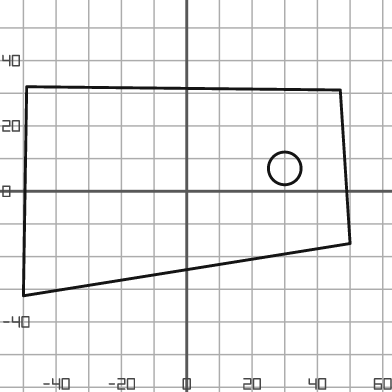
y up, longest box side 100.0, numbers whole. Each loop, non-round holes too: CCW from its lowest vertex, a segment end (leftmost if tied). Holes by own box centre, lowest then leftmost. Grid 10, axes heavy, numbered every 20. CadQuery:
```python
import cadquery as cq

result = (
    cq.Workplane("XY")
    .moveTo(-50.0, -32.0)
    .lineTo(50.0, -16.0)
    .lineTo(47.0, 31.0)
    .lineTo(-49.0, 32.0)
    .close()
    .moveTo(30.0, 7.0)
    .circle(5.0)
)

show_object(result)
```